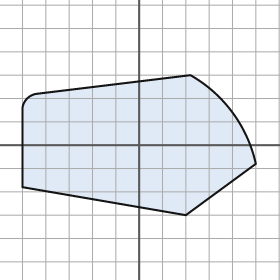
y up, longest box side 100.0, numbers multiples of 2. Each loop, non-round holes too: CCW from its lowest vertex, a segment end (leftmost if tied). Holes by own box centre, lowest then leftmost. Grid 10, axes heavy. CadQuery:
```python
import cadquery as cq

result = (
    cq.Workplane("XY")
    .moveTo(20.0, -30.0)
    .lineTo(50.0, -8.0)
    .threePointArc((40.0, 14.0), (22.0, 30.0))
    .lineTo(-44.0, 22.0)
    .threePointArc((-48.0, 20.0), (-50.0, 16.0))
    .lineTo(-50.0, -18.0)
    .close()
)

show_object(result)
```